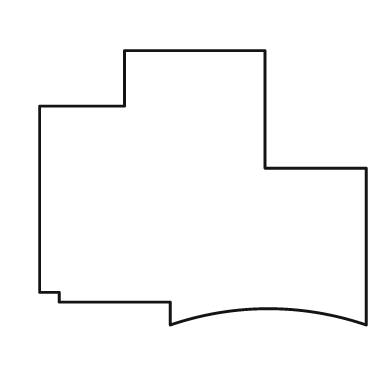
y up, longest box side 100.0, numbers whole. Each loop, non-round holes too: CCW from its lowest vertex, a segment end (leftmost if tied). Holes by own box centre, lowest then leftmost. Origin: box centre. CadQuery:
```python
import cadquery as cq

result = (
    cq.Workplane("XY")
    .moveTo(-10.0, -42.0)
    .threePointArc((20.0, -37.0), (50.0, -42.0))
    .lineTo(50.0, 6.0)
    .lineTo(19.0, 6.0)
    .lineTo(19.0, 42.0)
    .lineTo(-24.0, 42.0)
    .lineTo(-24.0, 25.0)
    .lineTo(-50.0, 25.0)
    .lineTo(-50.0, -32.0)
    .lineTo(-44.0, -32.0)
    .lineTo(-44.0, -35.0)
    .lineTo(-10.0, -35.0)
    .close()
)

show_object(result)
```